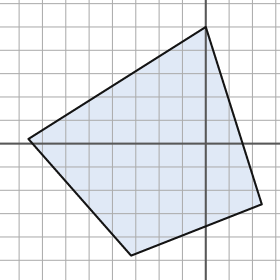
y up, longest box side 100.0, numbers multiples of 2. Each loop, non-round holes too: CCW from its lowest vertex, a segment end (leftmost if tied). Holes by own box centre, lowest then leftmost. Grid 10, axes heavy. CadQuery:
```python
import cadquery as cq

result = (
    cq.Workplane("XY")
    .moveTo(-32.0, -48.0)
    .lineTo(24.0, -26.0)
    .lineTo(0.0, 50.0)
    .lineTo(-76.0, 2.0)
    .close()
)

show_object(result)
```